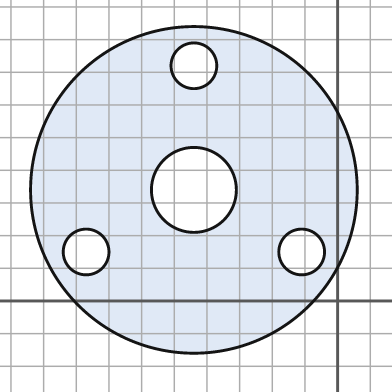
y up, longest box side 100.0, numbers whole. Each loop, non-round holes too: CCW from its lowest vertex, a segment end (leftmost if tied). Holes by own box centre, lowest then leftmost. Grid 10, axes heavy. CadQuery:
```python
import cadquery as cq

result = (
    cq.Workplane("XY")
    .moveTo(-44.0, 34.0)
    .circle(50.0)
    .moveTo(-77.0, 15.0)
    .circle(7.0)
    .moveTo(-11.0, 15.0)
    .circle(7.0)
    .moveTo(-44.0, 34.0)
    .circle(13.0)
    .moveTo(-44.0, 72.0)
    .circle(7.0)
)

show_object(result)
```